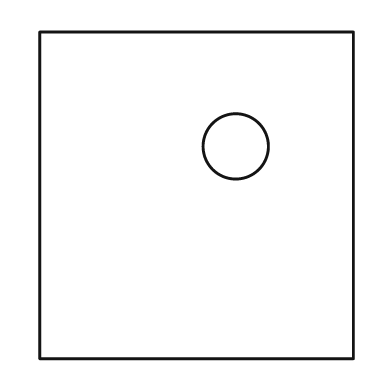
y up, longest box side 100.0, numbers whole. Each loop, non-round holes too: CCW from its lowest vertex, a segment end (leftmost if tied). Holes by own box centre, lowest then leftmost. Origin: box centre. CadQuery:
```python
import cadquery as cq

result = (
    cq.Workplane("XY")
    .moveTo(-48.0, -50.0)
    .lineTo(48.0, -50.0)
    .lineTo(48.0, 50.0)
    .lineTo(-48.0, 50.0)
    .close()
    .moveTo(12.0, 15.0)
    .circle(10.0)
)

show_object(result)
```